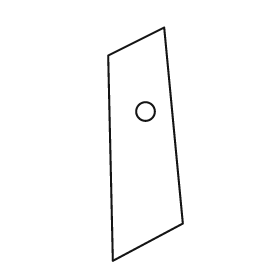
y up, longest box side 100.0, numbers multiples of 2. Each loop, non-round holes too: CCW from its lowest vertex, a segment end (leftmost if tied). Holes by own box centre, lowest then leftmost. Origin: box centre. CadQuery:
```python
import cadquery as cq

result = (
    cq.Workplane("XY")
    .moveTo(-14.0, -50.0)
    .lineTo(16.0, -34.0)
    .lineTo(8.0, 50.0)
    .lineTo(-16.0, 38.0)
    .close()
    .moveTo(0.0, 14.0)
    .circle(4.0)
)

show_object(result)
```